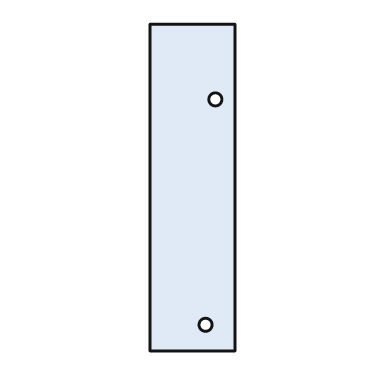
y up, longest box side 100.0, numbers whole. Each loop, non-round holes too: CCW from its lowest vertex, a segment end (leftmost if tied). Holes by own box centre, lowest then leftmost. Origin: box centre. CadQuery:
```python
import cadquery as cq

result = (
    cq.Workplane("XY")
    .moveTo(-13.0, -50.0)
    .lineTo(13.0, -50.0)
    .lineTo(13.0, 50.0)
    .lineTo(-13.0, 50.0)
    .close()
    .moveTo(4.0, -42.0)
    .circle(2.0)
    .moveTo(7.0, 27.0)
    .circle(2.0)
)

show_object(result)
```